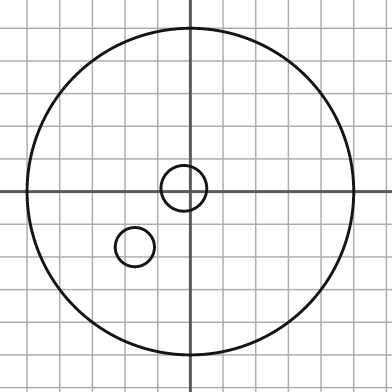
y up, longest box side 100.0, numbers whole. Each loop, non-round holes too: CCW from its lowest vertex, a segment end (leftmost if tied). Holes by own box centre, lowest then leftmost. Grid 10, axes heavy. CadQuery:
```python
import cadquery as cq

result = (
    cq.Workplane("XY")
    .moveTo(0.0, 0.0)
    .circle(50.0)
    .moveTo(-17.0, -17.0)
    .circle(6.0)
    .moveTo(-2.0, 1.0)
    .circle(7.0)
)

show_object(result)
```